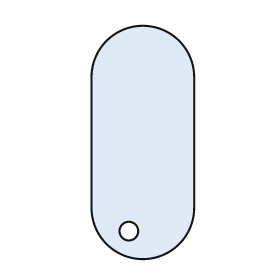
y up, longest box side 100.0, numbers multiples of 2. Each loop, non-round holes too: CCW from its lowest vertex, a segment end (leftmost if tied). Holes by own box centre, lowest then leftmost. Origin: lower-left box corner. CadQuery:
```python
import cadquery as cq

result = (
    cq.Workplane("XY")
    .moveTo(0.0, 22.0)
    .threePointArc((22.0, 0.0), (44.0, 22.0))
    .lineTo(44.0, 78.0)
    .threePointArc((22.0, 100.0), (0.0, 78.0))
    .close()
    .moveTo(16.0, 12.0)
    .circle(4.0)
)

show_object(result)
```